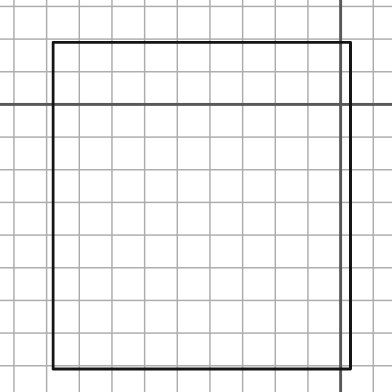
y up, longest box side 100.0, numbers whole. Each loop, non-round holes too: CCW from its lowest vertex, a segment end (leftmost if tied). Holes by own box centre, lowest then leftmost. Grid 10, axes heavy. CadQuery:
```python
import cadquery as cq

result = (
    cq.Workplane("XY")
    .moveTo(-88.0, -81.0)
    .lineTo(3.0, -81.0)
    .lineTo(3.0, 19.0)
    .lineTo(-88.0, 19.0)
    .close()
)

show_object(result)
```